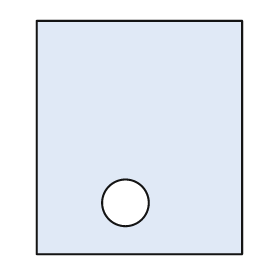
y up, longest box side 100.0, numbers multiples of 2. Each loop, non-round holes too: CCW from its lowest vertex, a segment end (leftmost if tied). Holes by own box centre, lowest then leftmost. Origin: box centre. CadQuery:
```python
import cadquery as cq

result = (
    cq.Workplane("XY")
    .moveTo(-44.0, -50.0)
    .lineTo(44.0, -50.0)
    .lineTo(44.0, 50.0)
    .lineTo(-44.0, 50.0)
    .close()
    .moveTo(-6.0, -28.0)
    .circle(10.0)
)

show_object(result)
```